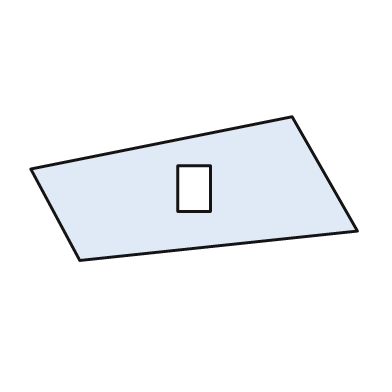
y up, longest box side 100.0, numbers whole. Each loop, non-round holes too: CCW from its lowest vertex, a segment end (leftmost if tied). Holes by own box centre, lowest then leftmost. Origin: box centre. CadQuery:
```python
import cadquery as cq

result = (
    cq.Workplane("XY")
    .moveTo(-35.0, -22.0)
    .lineTo(50.0, -13.0)
    .lineTo(30.0, 22.0)
    .lineTo(-50.0, 6.0)
    .close()
    .moveTo(-5.0, -7.0)
    .lineTo(5.0, -7.0)
    .lineTo(5.0, 7.0)
    .lineTo(-5.0, 7.0)
    .close()
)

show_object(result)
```